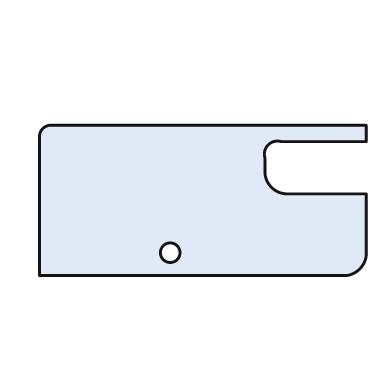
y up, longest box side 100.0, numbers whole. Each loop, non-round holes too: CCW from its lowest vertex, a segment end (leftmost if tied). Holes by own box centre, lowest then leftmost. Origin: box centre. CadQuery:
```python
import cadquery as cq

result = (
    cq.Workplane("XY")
    .moveTo(-50.0, -23.0)
    .lineTo(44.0, -23.0)
    .threePointArc((48.0, -21.0), (50.0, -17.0))
    .lineTo(50.0, 2.0)
    .lineTo(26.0, 2.0)
    .threePointArc((21.0, 4.0), (19.0, 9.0))
    .lineTo(19.0, 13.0)
    .threePointArc((20.0, 17.0), (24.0, 18.0))
    .lineTo(50.0, 18.0)
    .lineTo(50.0, 23.0)
    .lineTo(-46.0, 23.0)
    .threePointArc((-49.0, 22.0), (-50.0, 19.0))
    .close()
    .moveTo(-10.0, -16.0)
    .circle(3.0)
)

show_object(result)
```